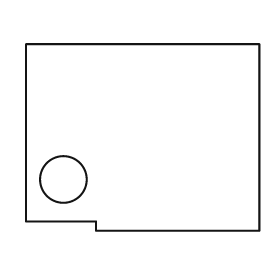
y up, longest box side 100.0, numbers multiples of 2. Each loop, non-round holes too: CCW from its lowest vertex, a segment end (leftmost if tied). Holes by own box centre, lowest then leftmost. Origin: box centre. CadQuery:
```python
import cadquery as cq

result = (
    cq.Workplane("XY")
    .moveTo(-20.0, -40.0)
    .lineTo(50.0, -40.0)
    .lineTo(50.0, 40.0)
    .lineTo(-50.0, 40.0)
    .lineTo(-50.0, -36.0)
    .lineTo(-20.0, -36.0)
    .close()
    .moveTo(-34.0, -18.0)
    .circle(10.0)
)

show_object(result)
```